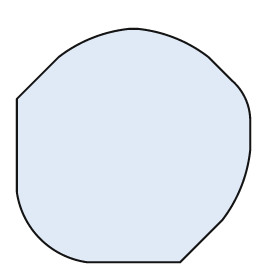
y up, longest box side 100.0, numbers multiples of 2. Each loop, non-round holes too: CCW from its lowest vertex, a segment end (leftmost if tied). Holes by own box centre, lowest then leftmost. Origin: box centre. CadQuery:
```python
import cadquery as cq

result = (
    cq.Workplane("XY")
    .moveTo(-20.0, -50.0)
    .lineTo(20.0, -50.0)
    .lineTo(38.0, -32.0)
    .threePointArc((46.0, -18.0), (50.0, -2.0))
    .lineTo(50.0, 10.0)
    .threePointArc((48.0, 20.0), (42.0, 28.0))
    .lineTo(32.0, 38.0)
    .threePointArc((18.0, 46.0), (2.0, 50.0))
    .lineTo(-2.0, 50.0)
    .threePointArc((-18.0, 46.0), (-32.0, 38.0))
    .lineTo(-50.0, 20.0)
    .lineTo(-50.0, -20.0)
    .threePointArc((-40.0, -40.0), (-20.0, -50.0))
    .close()
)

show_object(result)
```